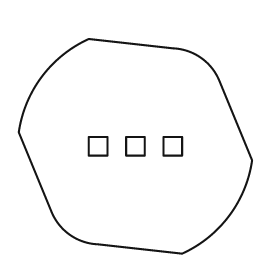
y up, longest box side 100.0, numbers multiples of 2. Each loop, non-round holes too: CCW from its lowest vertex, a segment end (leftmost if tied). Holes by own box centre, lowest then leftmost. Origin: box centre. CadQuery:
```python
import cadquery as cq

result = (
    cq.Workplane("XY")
    .moveTo(20.0, -46.0)
    .threePointArc((40.0, -30.0), (50.0, -6.0))
    .lineTo(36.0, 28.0)
    .threePointArc((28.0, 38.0), (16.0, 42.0))
    .lineTo(-20.0, 46.0)
    .threePointArc((-40.0, 30.0), (-50.0, 6.0))
    .lineTo(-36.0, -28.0)
    .threePointArc((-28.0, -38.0), (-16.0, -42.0))
    .close()
    .moveTo(-20.0, -4.0)
    .lineTo(-12.0, -4.0)
    .lineTo(-12.0, 4.0)
    .lineTo(-20.0, 4.0)
    .close()
    .moveTo(-4.0, -4.0)
    .lineTo(4.0, -4.0)
    .lineTo(4.0, 4.0)
    .lineTo(-4.0, 4.0)
    .close()
    .moveTo(12.0, -4.0)
    .lineTo(20.0, -4.0)
    .lineTo(20.0, 4.0)
    .lineTo(12.0, 4.0)
    .close()
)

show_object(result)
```